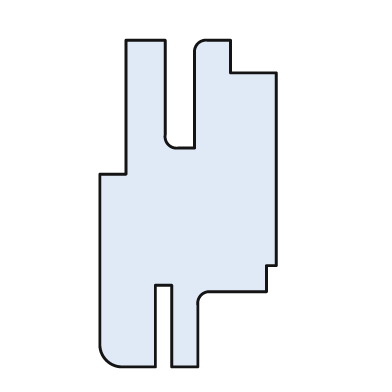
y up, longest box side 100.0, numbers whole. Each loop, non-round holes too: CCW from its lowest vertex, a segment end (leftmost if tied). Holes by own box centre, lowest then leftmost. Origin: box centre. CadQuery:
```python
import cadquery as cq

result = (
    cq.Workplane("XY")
    .moveTo(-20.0, -50.0)
    .lineTo(-10.0, -50.0)
    .lineTo(-10.0, -25.0)
    .lineTo(-5.0, -25.0)
    .lineTo(-5.0, -50.0)
    .lineTo(3.0, -50.0)
    .lineTo(3.0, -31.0)
    .threePointArc((4.0, -28.0), (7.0, -27.0))
    .lineTo(24.0, -27.0)
    .lineTo(24.0, -19.0)
    .lineTo(27.0, -19.0)
    .lineTo(27.0, 40.0)
    .lineTo(13.0, 40.0)
    .lineTo(13.0, 50.0)
    .lineTo(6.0, 50.0)
    .threePointArc((3.0, 49.0), (2.0, 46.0))
    .lineTo(2.0, 17.0)
    .lineTo(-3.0, 17.0)
    .threePointArc((-6.0, 18.0), (-7.0, 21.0))
    .lineTo(-7.0, 50.0)
    .lineTo(-19.0, 50.0)
    .lineTo(-19.0, 9.0)
    .lineTo(-27.0, 9.0)
    .lineTo(-27.0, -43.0)
    .threePointArc((-25.0, -48.0), (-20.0, -50.0))
    .close()
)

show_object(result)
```